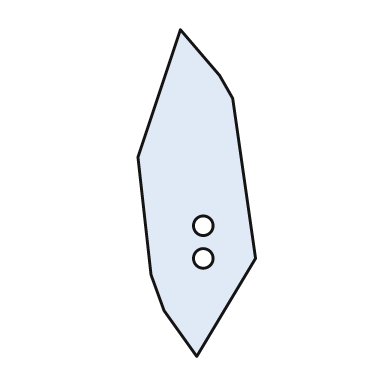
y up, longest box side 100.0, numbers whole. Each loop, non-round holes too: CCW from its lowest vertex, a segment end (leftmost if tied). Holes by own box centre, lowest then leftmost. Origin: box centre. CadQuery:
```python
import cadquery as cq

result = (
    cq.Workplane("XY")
    .moveTo(0.0, -50.0)
    .lineTo(18.0, -20.0)
    .lineTo(11.0, 29.0)
    .lineTo(7.0, 36.0)
    .lineTo(-5.0, 50.0)
    .lineTo(-18.0, 11.0)
    .lineTo(-14.0, -25.0)
    .lineTo(-10.0, -36.0)
    .close()
    .moveTo(2.0, -20.0)
    .circle(3.0)
    .moveTo(2.0, -10.0)
    .circle(3.0)
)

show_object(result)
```